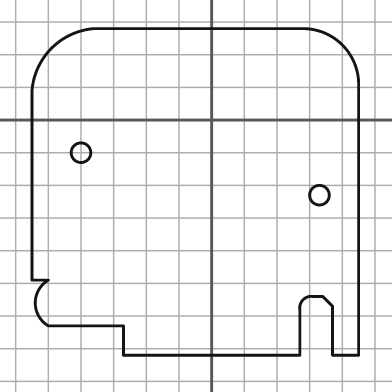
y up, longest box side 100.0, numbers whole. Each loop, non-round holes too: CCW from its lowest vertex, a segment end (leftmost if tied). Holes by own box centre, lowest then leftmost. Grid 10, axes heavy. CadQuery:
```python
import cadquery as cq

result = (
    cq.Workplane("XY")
    .moveTo(-27.0, -72.0)
    .lineTo(27.0, -72.0)
    .lineTo(27.0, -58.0)
    .threePointArc((28.0, -55.0), (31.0, -54.0))
    .lineTo(34.0, -54.0)
    .lineTo(37.0, -57.0)
    .lineTo(37.0, -72.0)
    .lineTo(45.0, -72.0)
    .lineTo(45.0, 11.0)
    .threePointArc((40.0, 23.0), (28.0, 28.0))
    .lineTo(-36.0, 28.0)
    .threePointArc((-49.0, 22.0), (-55.0, 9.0))
    .lineTo(-55.0, -49.0)
    .lineTo(-50.0, -49.0)
    .threePointArc((-54.0, -56.0), (-50.0, -63.0))
    .lineTo(-27.0, -63.0)
    .close()
    .moveTo(33.0, -23.0)
    .circle(3.0)
    .moveTo(-40.0, -10.0)
    .circle(3.0)
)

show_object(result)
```